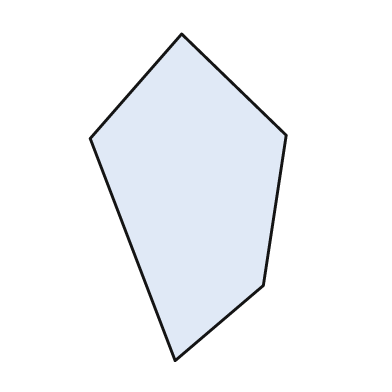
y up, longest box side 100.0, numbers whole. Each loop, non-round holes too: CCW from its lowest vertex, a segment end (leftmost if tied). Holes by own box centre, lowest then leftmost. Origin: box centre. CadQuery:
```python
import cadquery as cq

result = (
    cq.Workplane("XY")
    .moveTo(-4.0, -50.0)
    .lineTo(23.0, -27.0)
    .lineTo(30.0, 19.0)
    .lineTo(-2.0, 50.0)
    .lineTo(-30.0, 18.0)
    .close()
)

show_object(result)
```